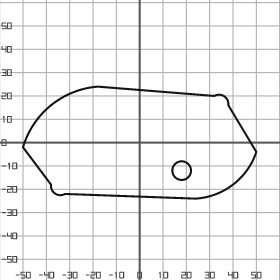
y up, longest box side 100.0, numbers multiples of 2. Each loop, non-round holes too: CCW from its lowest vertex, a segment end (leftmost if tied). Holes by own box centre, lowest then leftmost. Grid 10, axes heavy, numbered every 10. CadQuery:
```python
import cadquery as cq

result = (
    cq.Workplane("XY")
    .moveTo(24.0, -24.0)
    .threePointArc((40.0, -18.0), (50.0, -4.0))
    .lineTo(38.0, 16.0)
    .threePointArc((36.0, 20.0), (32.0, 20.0))
    .lineTo(-18.0, 24.0)
    .threePointArc((-38.0, 16.0), (-50.0, -2.0))
    .lineTo(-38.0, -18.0)
    .threePointArc((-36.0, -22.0), (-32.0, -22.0))
    .close()
    .moveTo(18.0, -12.0)
    .circle(4.0)
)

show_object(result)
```